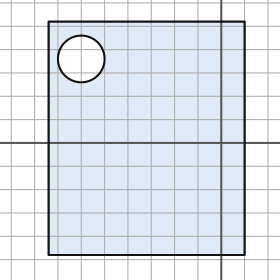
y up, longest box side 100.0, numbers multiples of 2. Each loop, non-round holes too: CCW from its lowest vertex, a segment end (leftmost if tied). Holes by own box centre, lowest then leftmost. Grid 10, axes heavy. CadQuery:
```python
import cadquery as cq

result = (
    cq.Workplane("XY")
    .moveTo(-74.0, -48.0)
    .lineTo(10.0, -48.0)
    .lineTo(10.0, 52.0)
    .lineTo(-74.0, 52.0)
    .close()
    .moveTo(-60.0, 36.0)
    .circle(10.0)
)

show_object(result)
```